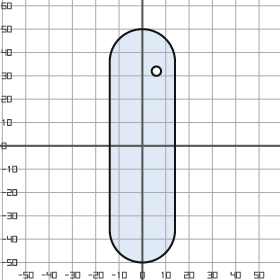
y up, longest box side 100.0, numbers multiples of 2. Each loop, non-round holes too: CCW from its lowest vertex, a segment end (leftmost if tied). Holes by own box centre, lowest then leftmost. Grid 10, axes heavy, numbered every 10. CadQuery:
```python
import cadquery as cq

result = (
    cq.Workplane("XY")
    .moveTo(-14.0, -36.0)
    .threePointArc((0.0, -50.0), (14.0, -36.0))
    .lineTo(14.0, 36.0)
    .threePointArc((0.0, 50.0), (-14.0, 36.0))
    .close()
    .moveTo(6.0, 32.0)
    .circle(2.0)
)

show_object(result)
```